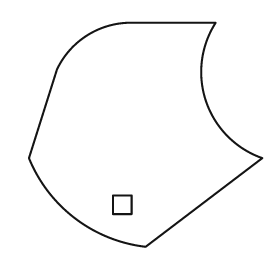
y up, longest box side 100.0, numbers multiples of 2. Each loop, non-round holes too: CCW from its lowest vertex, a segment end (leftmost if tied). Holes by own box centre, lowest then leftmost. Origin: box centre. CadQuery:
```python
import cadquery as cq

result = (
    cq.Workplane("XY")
    .moveTo(0.0, -48.0)
    .lineTo(50.0, -10.0)
    .threePointArc((26.0, 14.0), (30.0, 48.0))
    .lineTo(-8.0, 48.0)
    .threePointArc((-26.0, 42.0), (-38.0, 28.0))
    .lineTo(-50.0, -10.0)
    .threePointArc((-30.0, -36.0), (0.0, -48.0))
    .close()
    .moveTo(-14.0, -34.0)
    .lineTo(-6.0, -34.0)
    .lineTo(-6.0, -26.0)
    .lineTo(-14.0, -26.0)
    .close()
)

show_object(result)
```